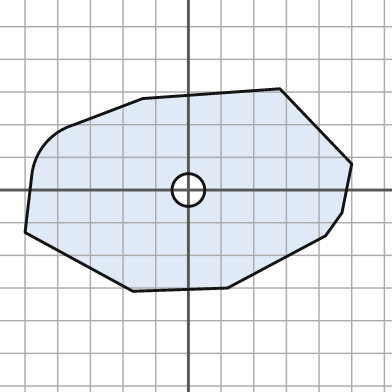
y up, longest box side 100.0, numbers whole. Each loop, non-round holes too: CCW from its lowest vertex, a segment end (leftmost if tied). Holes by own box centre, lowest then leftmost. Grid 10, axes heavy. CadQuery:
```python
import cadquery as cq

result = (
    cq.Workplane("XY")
    .moveTo(-17.0, -31.0)
    .lineTo(12.0, -30.0)
    .lineTo(42.0, -14.0)
    .lineTo(47.0, -7.0)
    .lineTo(50.0, 8.0)
    .lineTo(28.0, 31.0)
    .lineTo(-14.0, 28.0)
    .lineTo(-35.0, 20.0)
    .threePointArc((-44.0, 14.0), (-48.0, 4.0))
    .lineTo(-50.0, -13.0)
    .close()
    .moveTo(0.0, 0.0)
    .circle(5.0)
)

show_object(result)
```